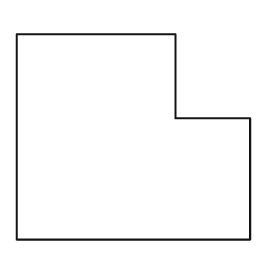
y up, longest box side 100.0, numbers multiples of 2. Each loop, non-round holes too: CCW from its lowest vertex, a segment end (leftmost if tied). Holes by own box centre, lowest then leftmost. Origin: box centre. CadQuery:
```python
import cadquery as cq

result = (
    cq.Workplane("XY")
    .moveTo(-50.0, -44.0)
    .lineTo(50.0, -44.0)
    .lineTo(50.0, 8.0)
    .lineTo(18.0, 8.0)
    .lineTo(18.0, 44.0)
    .lineTo(-50.0, 44.0)
    .close()
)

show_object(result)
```